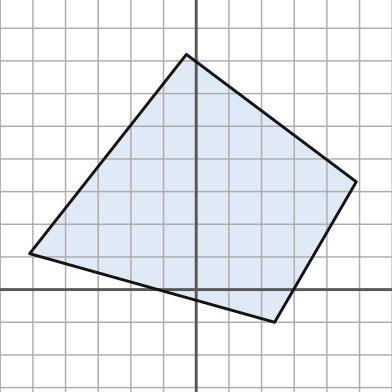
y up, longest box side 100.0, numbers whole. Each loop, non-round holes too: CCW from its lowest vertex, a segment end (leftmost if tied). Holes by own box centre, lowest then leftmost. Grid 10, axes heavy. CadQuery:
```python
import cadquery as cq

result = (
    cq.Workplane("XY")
    .moveTo(24.0, -10.0)
    .lineTo(49.0, 33.0)
    .lineTo(-3.0, 72.0)
    .lineTo(-51.0, 11.0)
    .close()
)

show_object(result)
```